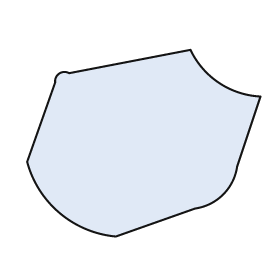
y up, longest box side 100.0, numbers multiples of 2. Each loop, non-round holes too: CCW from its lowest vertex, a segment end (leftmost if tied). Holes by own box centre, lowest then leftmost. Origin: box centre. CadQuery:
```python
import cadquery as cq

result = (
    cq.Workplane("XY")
    .moveTo(-12.0, -40.0)
    .lineTo(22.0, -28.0)
    .threePointArc((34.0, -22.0), (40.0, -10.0))
    .lineTo(50.0, 20.0)
    .threePointArc((32.0, 26.0), (20.0, 40.0))
    .lineTo(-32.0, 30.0)
    .threePointArc((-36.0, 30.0), (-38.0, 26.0))
    .lineTo(-50.0, -8.0)
    .threePointArc((-36.0, -30.0), (-12.0, -40.0))
    .close()
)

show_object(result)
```